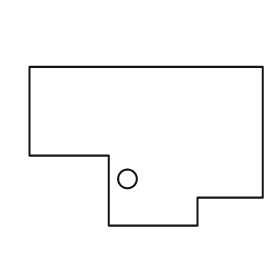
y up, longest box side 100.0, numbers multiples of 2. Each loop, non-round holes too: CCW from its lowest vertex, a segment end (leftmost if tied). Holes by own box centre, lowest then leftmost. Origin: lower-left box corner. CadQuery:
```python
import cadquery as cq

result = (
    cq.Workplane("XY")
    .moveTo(34.0, 0.0)
    .lineTo(72.0, 0.0)
    .lineTo(72.0, 12.0)
    .lineTo(100.0, 12.0)
    .lineTo(100.0, 68.0)
    .lineTo(0.0, 68.0)
    .lineTo(0.0, 30.0)
    .lineTo(34.0, 30.0)
    .close()
    .moveTo(42.0, 20.0)
    .circle(4.0)
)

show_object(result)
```